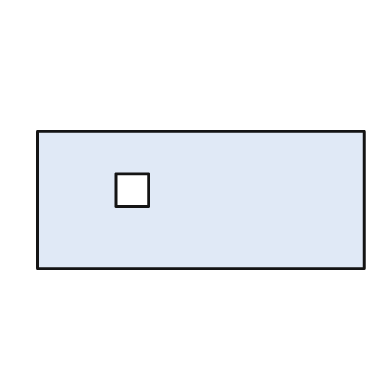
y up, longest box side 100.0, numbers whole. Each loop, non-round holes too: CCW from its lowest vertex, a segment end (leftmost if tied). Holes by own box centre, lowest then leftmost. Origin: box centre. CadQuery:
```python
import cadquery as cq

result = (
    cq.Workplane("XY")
    .moveTo(-50.0, -21.0)
    .lineTo(50.0, -21.0)
    .lineTo(50.0, 21.0)
    .lineTo(-50.0, 21.0)
    .close()
    .moveTo(-26.0, -2.0)
    .lineTo(-16.0, -2.0)
    .lineTo(-16.0, 8.0)
    .lineTo(-26.0, 8.0)
    .close()
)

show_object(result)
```